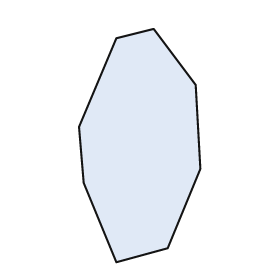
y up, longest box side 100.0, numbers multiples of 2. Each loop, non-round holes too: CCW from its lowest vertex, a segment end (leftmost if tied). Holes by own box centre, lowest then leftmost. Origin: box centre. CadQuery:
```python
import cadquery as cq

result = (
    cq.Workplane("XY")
    .moveTo(-10.0, -50.0)
    .lineTo(12.0, -44.0)
    .lineTo(26.0, -10.0)
    .lineTo(24.0, 26.0)
    .lineTo(6.0, 50.0)
    .lineTo(-10.0, 46.0)
    .lineTo(-26.0, 8.0)
    .lineTo(-24.0, -16.0)
    .close()
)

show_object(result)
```